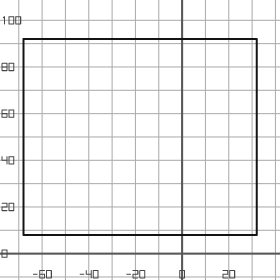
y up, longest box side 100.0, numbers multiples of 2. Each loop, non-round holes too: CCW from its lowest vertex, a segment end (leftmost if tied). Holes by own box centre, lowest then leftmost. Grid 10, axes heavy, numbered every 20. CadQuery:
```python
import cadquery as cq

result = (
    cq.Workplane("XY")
    .moveTo(-68.0, 8.0)
    .lineTo(32.0, 8.0)
    .lineTo(32.0, 92.0)
    .lineTo(-68.0, 92.0)
    .close()
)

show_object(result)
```